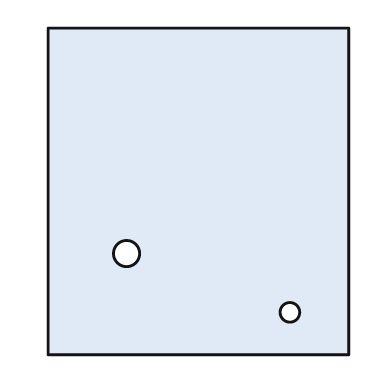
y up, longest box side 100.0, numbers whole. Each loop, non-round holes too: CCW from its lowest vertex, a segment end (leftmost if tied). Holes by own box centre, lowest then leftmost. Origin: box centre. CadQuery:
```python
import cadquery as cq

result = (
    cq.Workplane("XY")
    .moveTo(-46.0, -50.0)
    .lineTo(46.0, -50.0)
    .lineTo(46.0, 50.0)
    .lineTo(-46.0, 50.0)
    .close()
    .moveTo(28.0, -37.0)
    .circle(3.0)
    .moveTo(-22.0, -19.0)
    .circle(4.0)
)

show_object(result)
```